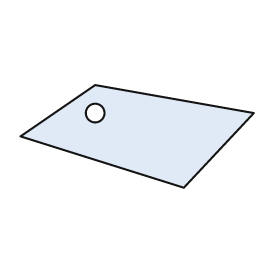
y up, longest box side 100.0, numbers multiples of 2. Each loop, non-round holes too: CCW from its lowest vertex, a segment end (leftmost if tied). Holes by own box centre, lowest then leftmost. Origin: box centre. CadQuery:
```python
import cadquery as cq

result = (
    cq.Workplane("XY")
    .moveTo(20.0, -22.0)
    .lineTo(50.0, 10.0)
    .lineTo(-18.0, 22.0)
    .lineTo(-50.0, 0.0)
    .close()
    .moveTo(-18.0, 10.0)
    .circle(4.0)
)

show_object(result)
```